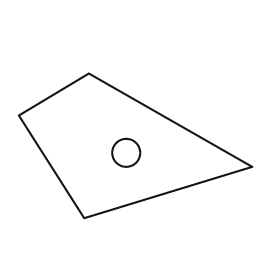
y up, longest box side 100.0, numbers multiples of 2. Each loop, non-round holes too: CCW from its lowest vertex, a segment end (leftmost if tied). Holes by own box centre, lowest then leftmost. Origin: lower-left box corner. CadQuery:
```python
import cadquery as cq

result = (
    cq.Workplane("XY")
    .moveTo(28.0, 0.0)
    .lineTo(100.0, 22.0)
    .lineTo(30.0, 62.0)
    .lineTo(0.0, 44.0)
    .close()
    .moveTo(46.0, 28.0)
    .circle(6.0)
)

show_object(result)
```